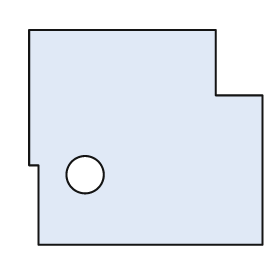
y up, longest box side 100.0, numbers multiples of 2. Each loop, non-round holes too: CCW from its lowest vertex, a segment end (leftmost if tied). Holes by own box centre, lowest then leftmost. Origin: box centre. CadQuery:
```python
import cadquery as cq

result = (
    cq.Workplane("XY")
    .moveTo(-46.0, -46.0)
    .lineTo(50.0, -46.0)
    .lineTo(50.0, 18.0)
    .lineTo(30.0, 18.0)
    .lineTo(30.0, 46.0)
    .lineTo(-50.0, 46.0)
    .lineTo(-50.0, -12.0)
    .lineTo(-46.0, -12.0)
    .close()
    .moveTo(-26.0, -16.0)
    .circle(8.0)
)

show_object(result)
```